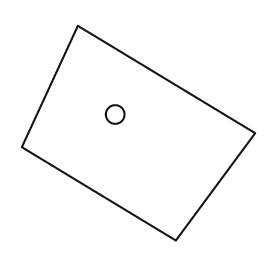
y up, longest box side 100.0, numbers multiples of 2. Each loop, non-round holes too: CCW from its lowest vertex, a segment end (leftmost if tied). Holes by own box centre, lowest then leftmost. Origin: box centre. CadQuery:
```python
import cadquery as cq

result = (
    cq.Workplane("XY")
    .moveTo(16.0, -46.0)
    .lineTo(50.0, 0.0)
    .lineTo(-26.0, 46.0)
    .lineTo(-50.0, -6.0)
    .close()
    .moveTo(-10.0, 8.0)
    .circle(4.0)
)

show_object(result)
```